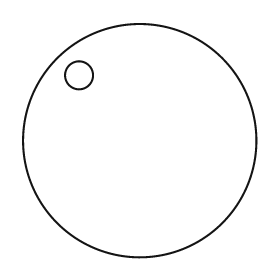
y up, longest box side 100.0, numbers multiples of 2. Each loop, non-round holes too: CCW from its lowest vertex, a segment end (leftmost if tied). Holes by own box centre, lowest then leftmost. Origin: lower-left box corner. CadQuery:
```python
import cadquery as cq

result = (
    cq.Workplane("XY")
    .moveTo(50.0, 50.0)
    .circle(50.0)
    .moveTo(24.0, 78.0)
    .circle(6.0)
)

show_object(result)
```